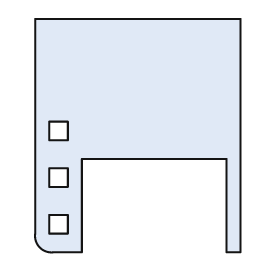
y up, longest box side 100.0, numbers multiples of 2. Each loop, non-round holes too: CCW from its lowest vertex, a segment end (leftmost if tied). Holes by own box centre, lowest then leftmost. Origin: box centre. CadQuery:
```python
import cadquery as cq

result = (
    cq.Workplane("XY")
    .moveTo(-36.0, -50.0)
    .lineTo(-24.0, -50.0)
    .lineTo(-24.0, -10.0)
    .lineTo(38.0, -10.0)
    .lineTo(38.0, -50.0)
    .lineTo(44.0, -50.0)
    .lineTo(44.0, 50.0)
    .lineTo(-44.0, 50.0)
    .lineTo(-44.0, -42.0)
    .threePointArc((-42.0, -48.0), (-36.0, -50.0))
    .close()
    .moveTo(-38.0, -42.0)
    .lineTo(-30.0, -42.0)
    .lineTo(-30.0, -34.0)
    .lineTo(-38.0, -34.0)
    .close()
    .moveTo(-38.0, -22.0)
    .lineTo(-30.0, -22.0)
    .lineTo(-30.0, -14.0)
    .lineTo(-38.0, -14.0)
    .close()
    .moveTo(-38.0, -2.0)
    .lineTo(-30.0, -2.0)
    .lineTo(-30.0, 6.0)
    .lineTo(-38.0, 6.0)
    .close()
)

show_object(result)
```